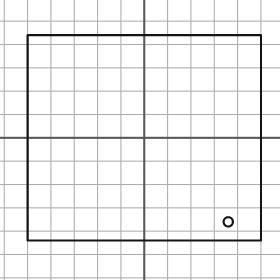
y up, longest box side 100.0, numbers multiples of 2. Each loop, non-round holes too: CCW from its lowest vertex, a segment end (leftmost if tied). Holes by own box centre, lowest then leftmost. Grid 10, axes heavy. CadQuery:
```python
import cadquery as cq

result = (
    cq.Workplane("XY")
    .moveTo(-50.0, -44.0)
    .lineTo(50.0, -44.0)
    .lineTo(50.0, 44.0)
    .lineTo(-50.0, 44.0)
    .close()
    .moveTo(36.0, -36.0)
    .circle(2.0)
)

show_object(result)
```